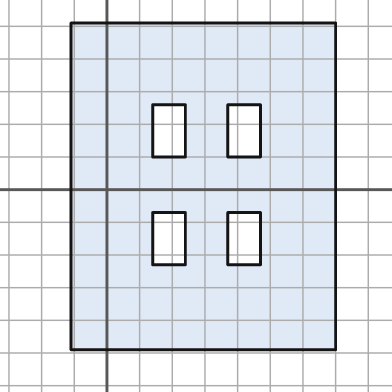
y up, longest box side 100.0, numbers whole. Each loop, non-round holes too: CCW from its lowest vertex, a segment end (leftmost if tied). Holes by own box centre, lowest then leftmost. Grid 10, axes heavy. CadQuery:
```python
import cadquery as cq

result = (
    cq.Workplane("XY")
    .moveTo(-11.0, -49.0)
    .lineTo(70.0, -49.0)
    .lineTo(70.0, 51.0)
    .lineTo(-11.0, 51.0)
    .close()
    .moveTo(14.0, -23.0)
    .lineTo(24.0, -23.0)
    .lineTo(24.0, -7.0)
    .lineTo(14.0, -7.0)
    .close()
    .moveTo(37.0, -23.0)
    .lineTo(47.0, -23.0)
    .lineTo(47.0, -7.0)
    .lineTo(37.0, -7.0)
    .close()
    .moveTo(14.0, 10.0)
    .lineTo(24.0, 10.0)
    .lineTo(24.0, 26.0)
    .lineTo(14.0, 26.0)
    .close()
    .moveTo(37.0, 10.0)
    .lineTo(47.0, 10.0)
    .lineTo(47.0, 26.0)
    .lineTo(37.0, 26.0)
    .close()
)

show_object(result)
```